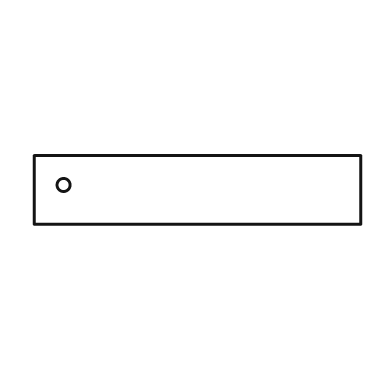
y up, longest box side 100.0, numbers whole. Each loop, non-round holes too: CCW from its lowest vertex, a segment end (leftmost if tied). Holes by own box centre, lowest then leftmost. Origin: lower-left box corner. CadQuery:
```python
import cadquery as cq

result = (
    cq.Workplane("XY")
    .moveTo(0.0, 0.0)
    .lineTo(100.0, 0.0)
    .lineTo(100.0, 21.0)
    .lineTo(0.0, 21.0)
    .close()
    .moveTo(9.0, 12.0)
    .circle(2.0)
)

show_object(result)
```